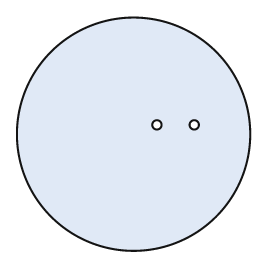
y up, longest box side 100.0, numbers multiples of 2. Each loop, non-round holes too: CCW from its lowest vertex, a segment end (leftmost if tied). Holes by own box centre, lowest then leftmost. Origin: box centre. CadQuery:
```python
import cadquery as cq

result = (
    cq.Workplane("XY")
    .moveTo(0.0, 0.0)
    .circle(50.0)
    .moveTo(10.0, 4.0)
    .circle(2.0)
    .moveTo(26.0, 4.0)
    .circle(2.0)
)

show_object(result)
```